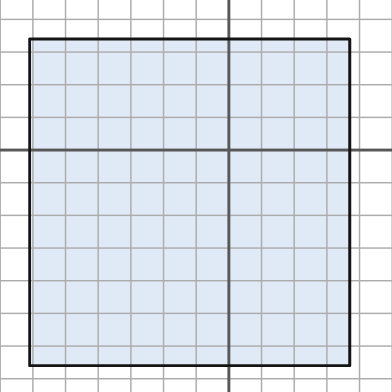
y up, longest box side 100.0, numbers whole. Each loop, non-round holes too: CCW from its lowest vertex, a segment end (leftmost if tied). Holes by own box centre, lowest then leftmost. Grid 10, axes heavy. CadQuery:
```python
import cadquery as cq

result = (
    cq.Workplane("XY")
    .moveTo(-61.0, -66.0)
    .lineTo(37.0, -66.0)
    .lineTo(37.0, 34.0)
    .lineTo(-61.0, 34.0)
    .close()
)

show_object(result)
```